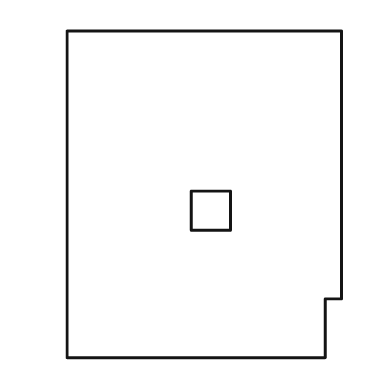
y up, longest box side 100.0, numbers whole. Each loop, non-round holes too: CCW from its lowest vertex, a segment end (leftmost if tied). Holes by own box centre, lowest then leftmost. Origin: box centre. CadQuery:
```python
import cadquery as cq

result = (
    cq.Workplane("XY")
    .moveTo(-42.0, -50.0)
    .lineTo(37.0, -50.0)
    .lineTo(37.0, -32.0)
    .lineTo(42.0, -32.0)
    .lineTo(42.0, 50.0)
    .lineTo(-42.0, 50.0)
    .close()
    .moveTo(-4.0, -11.0)
    .lineTo(8.0, -11.0)
    .lineTo(8.0, 1.0)
    .lineTo(-4.0, 1.0)
    .close()
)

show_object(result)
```